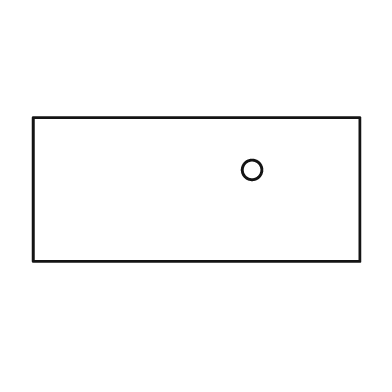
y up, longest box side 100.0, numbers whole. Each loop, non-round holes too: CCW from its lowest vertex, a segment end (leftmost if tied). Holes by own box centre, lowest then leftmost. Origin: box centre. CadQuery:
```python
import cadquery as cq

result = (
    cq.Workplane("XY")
    .moveTo(-50.0, -22.0)
    .lineTo(50.0, -22.0)
    .lineTo(50.0, 22.0)
    .lineTo(-50.0, 22.0)
    .close()
    .moveTo(17.0, 6.0)
    .circle(3.0)
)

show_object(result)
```